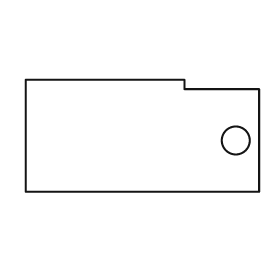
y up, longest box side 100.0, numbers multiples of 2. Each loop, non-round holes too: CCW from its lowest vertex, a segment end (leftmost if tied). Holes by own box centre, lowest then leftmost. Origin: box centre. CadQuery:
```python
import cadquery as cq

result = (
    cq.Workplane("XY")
    .moveTo(-50.0, -24.0)
    .lineTo(50.0, -24.0)
    .lineTo(50.0, 20.0)
    .lineTo(18.0, 20.0)
    .lineTo(18.0, 24.0)
    .lineTo(-50.0, 24.0)
    .close()
    .moveTo(40.0, -2.0)
    .circle(6.0)
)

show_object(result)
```